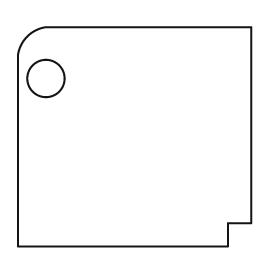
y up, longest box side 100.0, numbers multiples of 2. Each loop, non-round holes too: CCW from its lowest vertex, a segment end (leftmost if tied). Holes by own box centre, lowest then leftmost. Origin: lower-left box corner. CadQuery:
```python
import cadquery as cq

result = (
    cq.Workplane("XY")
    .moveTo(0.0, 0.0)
    .lineTo(90.0, 0.0)
    .lineTo(90.0, 10.0)
    .lineTo(100.0, 10.0)
    .lineTo(100.0, 94.0)
    .lineTo(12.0, 94.0)
    .threePointArc((4.0, 90.0), (0.0, 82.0))
    .close()
    .moveTo(12.0, 72.0)
    .circle(8.0)
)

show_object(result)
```